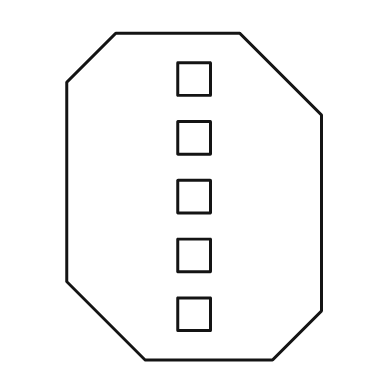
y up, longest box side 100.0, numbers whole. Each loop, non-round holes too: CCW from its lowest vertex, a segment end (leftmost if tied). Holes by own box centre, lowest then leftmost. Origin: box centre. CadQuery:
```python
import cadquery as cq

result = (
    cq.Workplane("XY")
    .moveTo(-15.0, -50.0)
    .lineTo(24.0, -50.0)
    .lineTo(39.0, -35.0)
    .lineTo(39.0, 25.0)
    .lineTo(14.0, 50.0)
    .lineTo(-24.0, 50.0)
    .lineTo(-39.0, 35.0)
    .lineTo(-39.0, -26.0)
    .close()
    .moveTo(-5.0, -41.0)
    .lineTo(5.0, -41.0)
    .lineTo(5.0, -31.0)
    .lineTo(-5.0, -31.0)
    .close()
    .moveTo(-5.0, -23.0)
    .lineTo(5.0, -23.0)
    .lineTo(5.0, -13.0)
    .lineTo(-5.0, -13.0)
    .close()
    .moveTo(-5.0, -5.0)
    .lineTo(5.0, -5.0)
    .lineTo(5.0, 5.0)
    .lineTo(-5.0, 5.0)
    .close()
    .moveTo(-5.0, 13.0)
    .lineTo(5.0, 13.0)
    .lineTo(5.0, 23.0)
    .lineTo(-5.0, 23.0)
    .close()
    .moveTo(-5.0, 31.0)
    .lineTo(5.0, 31.0)
    .lineTo(5.0, 41.0)
    .lineTo(-5.0, 41.0)
    .close()
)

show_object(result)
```